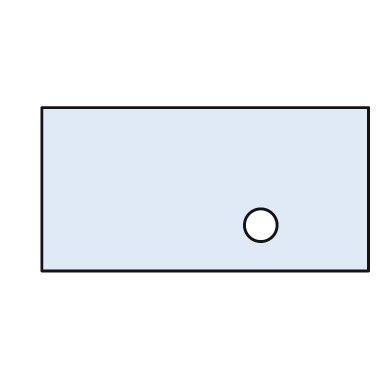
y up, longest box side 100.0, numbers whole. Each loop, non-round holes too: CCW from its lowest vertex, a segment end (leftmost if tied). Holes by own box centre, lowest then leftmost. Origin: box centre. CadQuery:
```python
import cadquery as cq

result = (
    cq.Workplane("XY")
    .moveTo(-50.0, -25.0)
    .lineTo(50.0, -25.0)
    .lineTo(50.0, 25.0)
    .lineTo(-50.0, 25.0)
    .close()
    .moveTo(17.0, -11.0)
    .circle(5.0)
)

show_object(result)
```